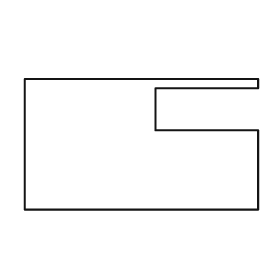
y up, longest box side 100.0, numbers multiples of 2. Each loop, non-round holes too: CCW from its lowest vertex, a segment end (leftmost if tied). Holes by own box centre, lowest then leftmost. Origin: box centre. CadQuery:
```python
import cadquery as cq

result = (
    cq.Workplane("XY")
    .moveTo(-50.0, -28.0)
    .lineTo(50.0, -28.0)
    .lineTo(50.0, 6.0)
    .lineTo(6.0, 6.0)
    .lineTo(6.0, 24.0)
    .lineTo(50.0, 24.0)
    .lineTo(50.0, 28.0)
    .lineTo(-50.0, 28.0)
    .close()
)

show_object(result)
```